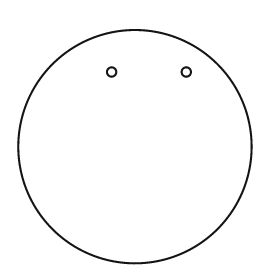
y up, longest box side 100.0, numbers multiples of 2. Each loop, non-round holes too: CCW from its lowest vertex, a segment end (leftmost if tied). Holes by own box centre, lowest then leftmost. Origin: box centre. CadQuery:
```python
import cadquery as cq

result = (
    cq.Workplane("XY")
    .moveTo(0.0, 0.0)
    .circle(50.0)
    .moveTo(-10.0, 32.0)
    .circle(2.0)
    .moveTo(22.0, 32.0)
    .circle(2.0)
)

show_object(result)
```